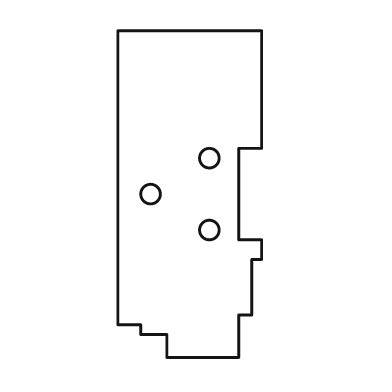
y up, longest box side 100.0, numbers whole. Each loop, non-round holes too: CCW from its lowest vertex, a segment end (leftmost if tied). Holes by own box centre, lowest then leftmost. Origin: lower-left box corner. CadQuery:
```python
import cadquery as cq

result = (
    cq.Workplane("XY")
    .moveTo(15.0, 0.0)
    .lineTo(37.0, 0.0)
    .lineTo(37.0, 13.0)
    .lineTo(41.0, 13.0)
    .lineTo(41.0, 30.0)
    .lineTo(44.0, 30.0)
    .lineTo(44.0, 36.0)
    .lineTo(37.0, 36.0)
    .lineTo(37.0, 64.0)
    .lineTo(44.0, 64.0)
    .lineTo(44.0, 100.0)
    .lineTo(0.0, 100.0)
    .lineTo(0.0, 10.0)
    .lineTo(7.0, 10.0)
    .lineTo(7.0, 7.0)
    .lineTo(15.0, 7.0)
    .close()
    .moveTo(28.0, 39.0)
    .circle(3.0)
    .moveTo(10.0, 50.0)
    .circle(3.0)
    .moveTo(28.0, 61.0)
    .circle(3.0)
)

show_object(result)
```